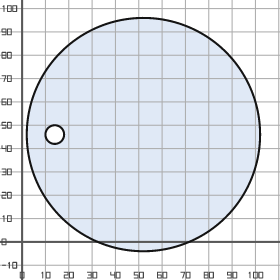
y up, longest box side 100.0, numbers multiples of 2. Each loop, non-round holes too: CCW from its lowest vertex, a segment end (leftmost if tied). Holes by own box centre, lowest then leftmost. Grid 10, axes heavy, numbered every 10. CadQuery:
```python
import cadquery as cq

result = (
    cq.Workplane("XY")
    .moveTo(52.0, 46.0)
    .circle(50.0)
    .moveTo(14.0, 46.0)
    .circle(4.0)
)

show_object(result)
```